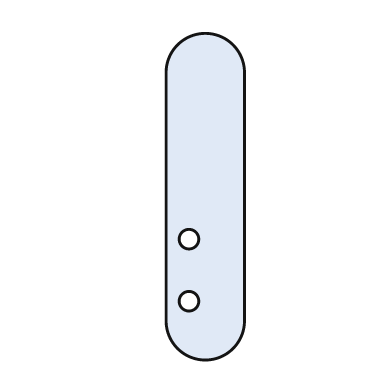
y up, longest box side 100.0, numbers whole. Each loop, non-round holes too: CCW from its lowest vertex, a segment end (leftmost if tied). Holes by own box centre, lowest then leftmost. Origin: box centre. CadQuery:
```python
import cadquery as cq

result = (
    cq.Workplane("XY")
    .moveTo(-12.0, -38.0)
    .threePointArc((0.0, -50.0), (12.0, -38.0))
    .lineTo(12.0, 38.0)
    .threePointArc((0.0, 50.0), (-12.0, 38.0))
    .close()
    .moveTo(-5.0, -32.0)
    .circle(3.0)
    .moveTo(-5.0, -13.0)
    .circle(3.0)
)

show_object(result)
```